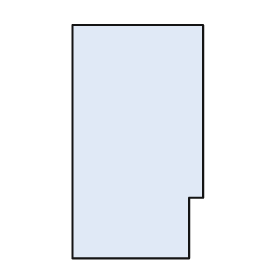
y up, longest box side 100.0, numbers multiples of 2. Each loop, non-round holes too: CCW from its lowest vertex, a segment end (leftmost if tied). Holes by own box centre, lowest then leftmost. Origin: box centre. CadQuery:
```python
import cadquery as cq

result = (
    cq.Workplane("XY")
    .moveTo(-28.0, -50.0)
    .lineTo(22.0, -50.0)
    .lineTo(22.0, -24.0)
    .lineTo(28.0, -24.0)
    .lineTo(28.0, 50.0)
    .lineTo(-28.0, 50.0)
    .close()
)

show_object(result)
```